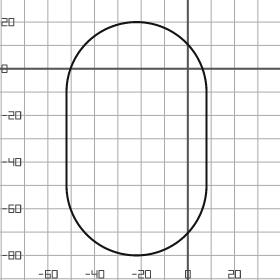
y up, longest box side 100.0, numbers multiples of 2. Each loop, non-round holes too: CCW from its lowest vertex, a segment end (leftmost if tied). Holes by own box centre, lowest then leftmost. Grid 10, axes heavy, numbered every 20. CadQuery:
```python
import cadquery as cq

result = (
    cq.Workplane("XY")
    .moveTo(-52.0, -50.0)
    .threePointArc((-22.0, -80.0), (8.0, -50.0))
    .lineTo(8.0, -10.0)
    .threePointArc((-22.0, 20.0), (-52.0, -10.0))
    .close()
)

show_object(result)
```